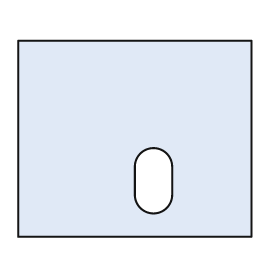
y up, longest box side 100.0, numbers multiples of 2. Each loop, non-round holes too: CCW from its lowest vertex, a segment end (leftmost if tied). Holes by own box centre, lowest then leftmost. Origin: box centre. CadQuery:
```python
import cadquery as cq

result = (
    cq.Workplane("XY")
    .moveTo(-50.0, -42.0)
    .lineTo(50.0, -42.0)
    .lineTo(50.0, 42.0)
    .lineTo(-50.0, 42.0)
    .close()
    .moveTo(0.0, -24.0)
    .threePointArc((8.0, -32.0), (16.0, -24.0))
    .lineTo(16.0, -12.0)
    .threePointArc((8.0, -4.0), (0.0, -12.0))
    .close()
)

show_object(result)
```